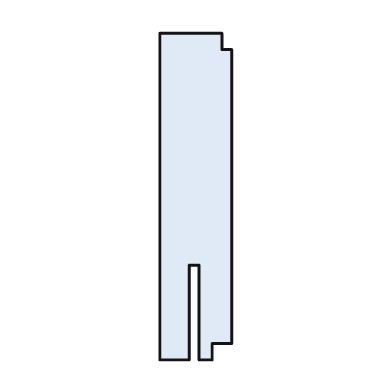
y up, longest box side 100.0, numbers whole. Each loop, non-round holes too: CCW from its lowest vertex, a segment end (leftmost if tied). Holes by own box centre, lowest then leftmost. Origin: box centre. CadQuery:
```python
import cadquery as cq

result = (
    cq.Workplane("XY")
    .moveTo(-11.0, -50.0)
    .lineTo(-2.0, -50.0)
    .lineTo(-2.0, -21.0)
    .lineTo(1.0, -21.0)
    .lineTo(1.0, -50.0)
    .lineTo(5.0, -50.0)
    .lineTo(5.0, -45.0)
    .lineTo(11.0, -45.0)
    .lineTo(11.0, 45.0)
    .lineTo(8.0, 45.0)
    .lineTo(8.0, 50.0)
    .lineTo(-11.0, 50.0)
    .close()
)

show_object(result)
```